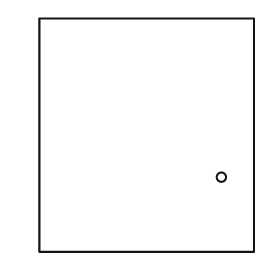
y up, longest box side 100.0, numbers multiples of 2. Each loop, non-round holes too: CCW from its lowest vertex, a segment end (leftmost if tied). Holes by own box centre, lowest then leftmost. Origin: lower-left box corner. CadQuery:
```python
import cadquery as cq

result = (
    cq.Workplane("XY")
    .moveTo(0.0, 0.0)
    .lineTo(92.0, 0.0)
    .lineTo(92.0, 100.0)
    .lineTo(0.0, 100.0)
    .close()
    .moveTo(78.0, 32.0)
    .circle(2.0)
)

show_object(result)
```